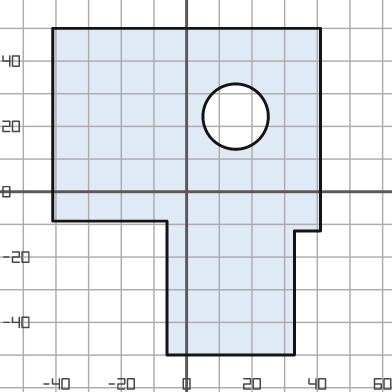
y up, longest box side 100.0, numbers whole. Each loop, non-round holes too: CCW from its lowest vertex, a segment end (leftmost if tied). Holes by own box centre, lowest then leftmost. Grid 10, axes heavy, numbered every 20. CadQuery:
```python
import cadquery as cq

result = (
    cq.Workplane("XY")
    .moveTo(-6.0, -50.0)
    .lineTo(33.0, -50.0)
    .lineTo(33.0, -12.0)
    .lineTo(41.0, -12.0)
    .lineTo(41.0, 50.0)
    .lineTo(-41.0, 50.0)
    .lineTo(-41.0, -9.0)
    .lineTo(-6.0, -9.0)
    .close()
    .moveTo(15.0, 23.0)
    .circle(10.0)
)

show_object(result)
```